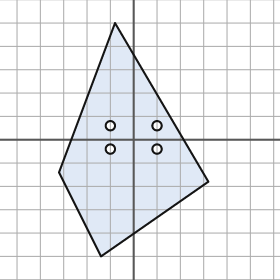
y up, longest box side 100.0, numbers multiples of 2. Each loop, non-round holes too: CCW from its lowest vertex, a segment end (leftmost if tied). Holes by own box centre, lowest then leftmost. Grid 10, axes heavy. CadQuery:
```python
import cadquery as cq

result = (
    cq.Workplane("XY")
    .moveTo(-14.0, -50.0)
    .lineTo(32.0, -18.0)
    .lineTo(-8.0, 50.0)
    .lineTo(-32.0, -14.0)
    .close()
    .moveTo(-10.0, -4.0)
    .circle(2.0)
    .moveTo(10.0, -4.0)
    .circle(2.0)
    .moveTo(-10.0, 6.0)
    .circle(2.0)
    .moveTo(10.0, 6.0)
    .circle(2.0)
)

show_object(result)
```